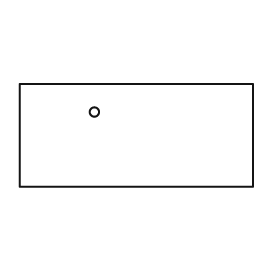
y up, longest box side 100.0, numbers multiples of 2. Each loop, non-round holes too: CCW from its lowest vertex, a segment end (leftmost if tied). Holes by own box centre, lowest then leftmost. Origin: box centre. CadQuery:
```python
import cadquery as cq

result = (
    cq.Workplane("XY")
    .moveTo(-50.0, -22.0)
    .lineTo(50.0, -22.0)
    .lineTo(50.0, 22.0)
    .lineTo(-50.0, 22.0)
    .close()
    .moveTo(-18.0, 10.0)
    .circle(2.0)
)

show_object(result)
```